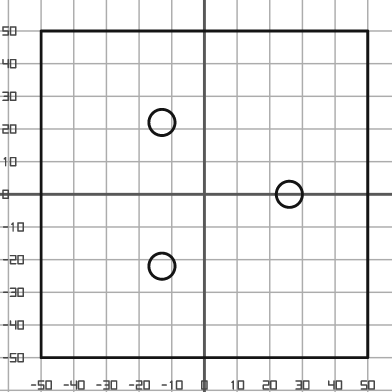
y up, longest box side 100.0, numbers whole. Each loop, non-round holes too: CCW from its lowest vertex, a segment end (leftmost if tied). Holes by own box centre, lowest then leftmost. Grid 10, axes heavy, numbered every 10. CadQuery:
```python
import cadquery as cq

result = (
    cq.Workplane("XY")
    .moveTo(-50.0, -50.0)
    .lineTo(50.0, -50.0)
    .lineTo(50.0, 50.0)
    .lineTo(-50.0, 50.0)
    .close()
    .moveTo(-13.0, -22.0)
    .circle(4.0)
    .moveTo(26.0, 0.0)
    .circle(4.0)
    .moveTo(-13.0, 22.0)
    .circle(4.0)
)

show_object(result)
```